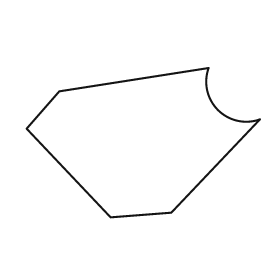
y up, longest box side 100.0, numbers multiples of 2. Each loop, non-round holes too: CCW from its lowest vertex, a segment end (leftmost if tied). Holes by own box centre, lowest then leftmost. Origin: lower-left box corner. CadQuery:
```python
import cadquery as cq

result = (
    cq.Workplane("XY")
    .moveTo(36.0, 0.0)
    .lineTo(62.0, 2.0)
    .lineTo(100.0, 42.0)
    .threePointArc((82.0, 46.0), (78.0, 64.0))
    .lineTo(14.0, 54.0)
    .lineTo(0.0, 38.0)
    .close()
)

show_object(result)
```